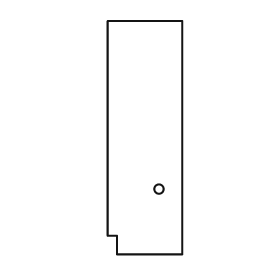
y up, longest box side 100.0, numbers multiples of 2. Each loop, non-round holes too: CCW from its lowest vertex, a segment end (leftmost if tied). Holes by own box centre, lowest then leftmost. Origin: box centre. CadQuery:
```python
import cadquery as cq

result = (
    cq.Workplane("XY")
    .moveTo(-12.0, -50.0)
    .lineTo(16.0, -50.0)
    .lineTo(16.0, 50.0)
    .lineTo(-16.0, 50.0)
    .lineTo(-16.0, -42.0)
    .lineTo(-12.0, -42.0)
    .close()
    .moveTo(6.0, -22.0)
    .circle(2.0)
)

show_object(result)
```